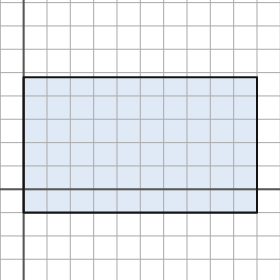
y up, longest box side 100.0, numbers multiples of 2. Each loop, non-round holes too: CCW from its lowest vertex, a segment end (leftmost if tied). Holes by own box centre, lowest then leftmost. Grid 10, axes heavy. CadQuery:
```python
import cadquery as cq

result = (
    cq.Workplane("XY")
    .moveTo(0.0, -10.0)
    .lineTo(100.0, -10.0)
    .lineTo(100.0, 48.0)
    .lineTo(0.0, 48.0)
    .close()
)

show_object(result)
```